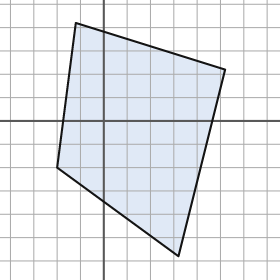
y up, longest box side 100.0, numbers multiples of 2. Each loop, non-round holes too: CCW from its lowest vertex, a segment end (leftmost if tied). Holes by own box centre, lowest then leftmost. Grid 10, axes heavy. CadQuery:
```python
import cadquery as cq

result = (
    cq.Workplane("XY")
    .moveTo(32.0, -58.0)
    .lineTo(52.0, 22.0)
    .lineTo(-12.0, 42.0)
    .lineTo(-20.0, -20.0)
    .close()
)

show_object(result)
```